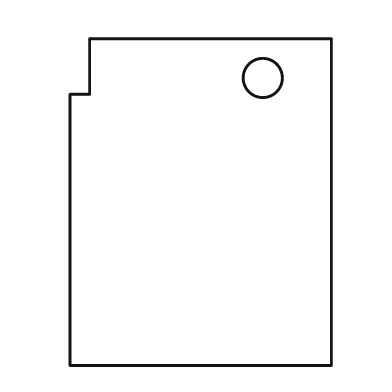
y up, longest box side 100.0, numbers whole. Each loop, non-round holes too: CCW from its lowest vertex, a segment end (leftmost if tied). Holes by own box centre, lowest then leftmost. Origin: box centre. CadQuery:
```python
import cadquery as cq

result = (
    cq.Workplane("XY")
    .moveTo(-40.0, -50.0)
    .lineTo(40.0, -50.0)
    .lineTo(40.0, 50.0)
    .lineTo(-34.0, 50.0)
    .lineTo(-34.0, 33.0)
    .lineTo(-40.0, 33.0)
    .close()
    .moveTo(19.0, 38.0)
    .circle(6.0)
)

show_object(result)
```